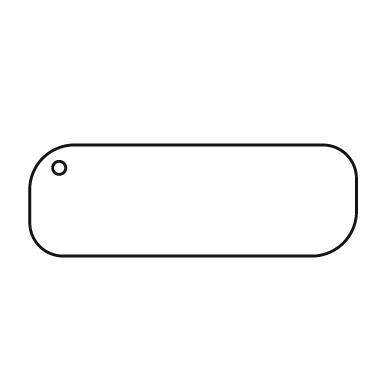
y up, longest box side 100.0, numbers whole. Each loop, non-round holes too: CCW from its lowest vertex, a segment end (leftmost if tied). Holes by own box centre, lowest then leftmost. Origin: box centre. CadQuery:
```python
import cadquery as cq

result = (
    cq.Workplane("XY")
    .moveTo(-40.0, -17.0)
    .lineTo(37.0, -17.0)
    .threePointArc((46.0, -13.0), (50.0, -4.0))
    .lineTo(50.0, 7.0)
    .threePointArc((47.0, 14.0), (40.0, 17.0))
    .lineTo(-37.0, 17.0)
    .threePointArc((-46.0, 13.0), (-50.0, 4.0))
    .lineTo(-50.0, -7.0)
    .threePointArc((-47.0, -14.0), (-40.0, -17.0))
    .close()
    .moveTo(-41.0, 10.0)
    .circle(2.0)
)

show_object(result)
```